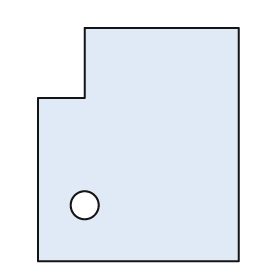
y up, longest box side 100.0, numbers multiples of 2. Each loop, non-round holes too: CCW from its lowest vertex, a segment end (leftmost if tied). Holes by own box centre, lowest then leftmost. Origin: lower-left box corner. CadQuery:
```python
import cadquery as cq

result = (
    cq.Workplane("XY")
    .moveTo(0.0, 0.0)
    .lineTo(86.0, 0.0)
    .lineTo(86.0, 100.0)
    .lineTo(20.0, 100.0)
    .lineTo(20.0, 70.0)
    .lineTo(0.0, 70.0)
    .close()
    .moveTo(20.0, 24.0)
    .circle(6.0)
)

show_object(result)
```